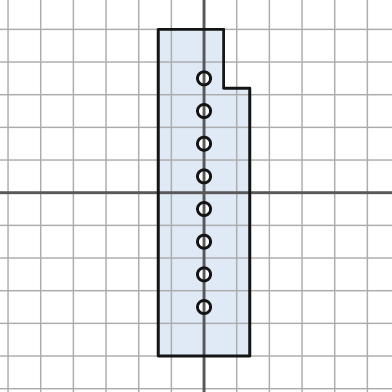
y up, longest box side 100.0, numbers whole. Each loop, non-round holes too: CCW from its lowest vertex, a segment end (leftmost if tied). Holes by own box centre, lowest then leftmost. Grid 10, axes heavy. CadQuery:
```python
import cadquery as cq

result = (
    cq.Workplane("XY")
    .moveTo(-14.0, -50.0)
    .lineTo(14.0, -50.0)
    .lineTo(14.0, 32.0)
    .lineTo(6.0, 32.0)
    .lineTo(6.0, 50.0)
    .lineTo(-14.0, 50.0)
    .close()
    .moveTo(0.0, -35.0)
    .circle(2.0)
    .moveTo(0.0, -25.0)
    .circle(2.0)
    .moveTo(0.0, -15.0)
    .circle(2.0)
    .moveTo(0.0, -5.0)
    .circle(2.0)
    .moveTo(0.0, 5.0)
    .circle(2.0)
    .moveTo(0.0, 15.0)
    .circle(2.0)
    .moveTo(0.0, 25.0)
    .circle(2.0)
    .moveTo(0.0, 35.0)
    .circle(2.0)
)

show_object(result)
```